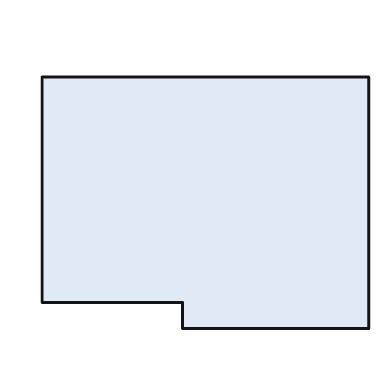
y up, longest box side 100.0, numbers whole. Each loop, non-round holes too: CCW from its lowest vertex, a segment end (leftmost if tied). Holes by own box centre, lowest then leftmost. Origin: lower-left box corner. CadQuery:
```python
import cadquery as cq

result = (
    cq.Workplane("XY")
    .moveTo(43.0, 0.0)
    .lineTo(100.0, 0.0)
    .lineTo(100.0, 77.0)
    .lineTo(0.0, 77.0)
    .lineTo(0.0, 8.0)
    .lineTo(43.0, 8.0)
    .close()
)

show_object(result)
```